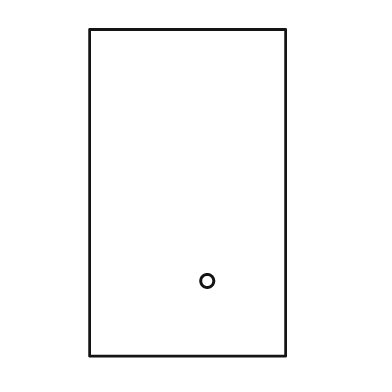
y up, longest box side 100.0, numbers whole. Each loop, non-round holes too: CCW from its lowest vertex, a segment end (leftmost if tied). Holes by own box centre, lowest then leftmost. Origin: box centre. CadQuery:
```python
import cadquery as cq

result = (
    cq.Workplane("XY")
    .moveTo(-30.0, -50.0)
    .lineTo(30.0, -50.0)
    .lineTo(30.0, 50.0)
    .lineTo(-30.0, 50.0)
    .close()
    .moveTo(6.0, -27.0)
    .circle(2.0)
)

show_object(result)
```